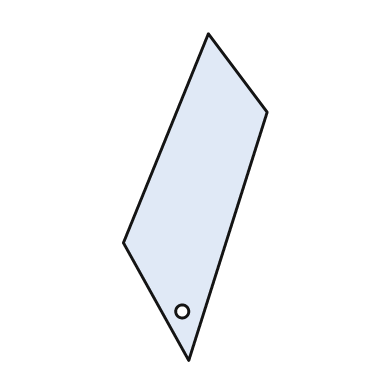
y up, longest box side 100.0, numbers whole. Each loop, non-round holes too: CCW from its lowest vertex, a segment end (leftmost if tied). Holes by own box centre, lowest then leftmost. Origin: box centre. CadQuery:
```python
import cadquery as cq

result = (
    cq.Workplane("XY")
    .moveTo(-2.0, -50.0)
    .lineTo(22.0, 26.0)
    .lineTo(4.0, 50.0)
    .lineTo(-22.0, -14.0)
    .close()
    .moveTo(-4.0, -35.0)
    .circle(2.0)
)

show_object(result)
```